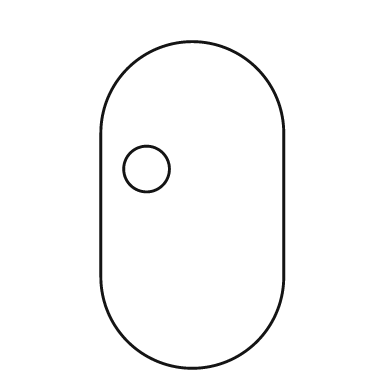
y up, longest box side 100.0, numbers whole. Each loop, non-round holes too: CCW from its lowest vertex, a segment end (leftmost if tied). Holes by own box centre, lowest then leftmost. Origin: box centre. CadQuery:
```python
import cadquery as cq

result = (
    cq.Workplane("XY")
    .moveTo(-28.0, -22.0)
    .threePointArc((0.0, -50.0), (28.0, -22.0))
    .lineTo(28.0, 22.0)
    .threePointArc((0.0, 50.0), (-28.0, 22.0))
    .close()
    .moveTo(-14.0, 11.0)
    .circle(7.0)
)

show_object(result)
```